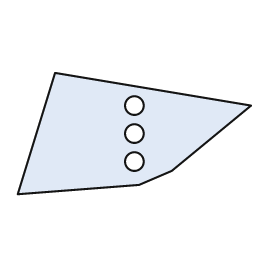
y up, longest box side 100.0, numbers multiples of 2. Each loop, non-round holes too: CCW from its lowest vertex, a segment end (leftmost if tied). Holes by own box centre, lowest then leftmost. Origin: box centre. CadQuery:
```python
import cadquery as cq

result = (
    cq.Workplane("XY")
    .moveTo(-50.0, -26.0)
    .lineTo(2.0, -22.0)
    .lineTo(16.0, -16.0)
    .lineTo(50.0, 12.0)
    .lineTo(-34.0, 26.0)
    .close()
    .moveTo(0.0, -12.0)
    .circle(4.0)
    .moveTo(0.0, 0.0)
    .circle(4.0)
    .moveTo(0.0, 12.0)
    .circle(4.0)
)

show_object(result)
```